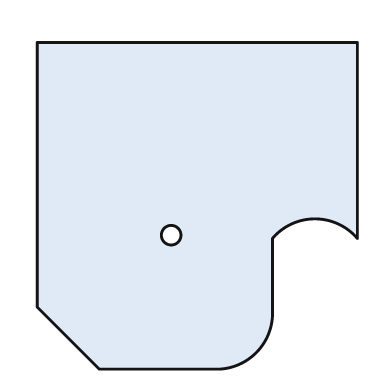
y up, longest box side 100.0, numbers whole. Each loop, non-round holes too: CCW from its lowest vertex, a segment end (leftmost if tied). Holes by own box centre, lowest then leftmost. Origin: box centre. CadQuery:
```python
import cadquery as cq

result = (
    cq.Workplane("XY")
    .moveTo(-30.0, -50.0)
    .lineTo(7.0, -50.0)
    .threePointArc((18.0, -45.0), (23.0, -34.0))
    .lineTo(23.0, -10.0)
    .threePointArc((36.0, -4.0), (49.0, -10.0))
    .lineTo(49.0, 50.0)
    .lineTo(-49.0, 50.0)
    .lineTo(-49.0, -31.0)
    .close()
    .moveTo(-8.0, -9.0)
    .circle(3.0)
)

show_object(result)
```